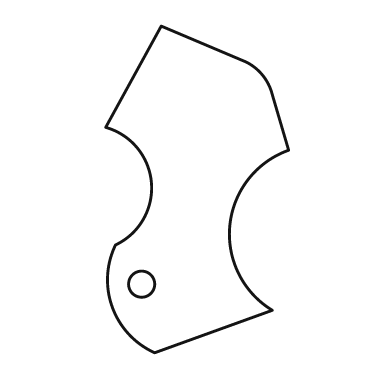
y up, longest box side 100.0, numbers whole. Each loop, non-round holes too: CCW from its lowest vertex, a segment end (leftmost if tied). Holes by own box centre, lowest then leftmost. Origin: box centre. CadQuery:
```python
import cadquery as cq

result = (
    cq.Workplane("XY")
    .moveTo(-13.0, -50.0)
    .lineTo(23.0, -37.0)
    .threePointArc((10.0, -11.0), (28.0, 12.0))
    .lineTo(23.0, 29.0)
    .threePointArc((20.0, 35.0), (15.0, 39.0))
    .lineTo(-11.0, 50.0)
    .lineTo(-28.0, 19.0)
    .threePointArc((-14.0, 2.0), (-25.0, -17.0))
    .threePointArc((-26.0, -36.0), (-13.0, -50.0))
    .close()
    .moveTo(-17.0, -29.0)
    .circle(4.0)
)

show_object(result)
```